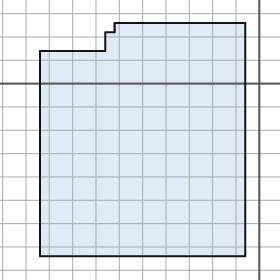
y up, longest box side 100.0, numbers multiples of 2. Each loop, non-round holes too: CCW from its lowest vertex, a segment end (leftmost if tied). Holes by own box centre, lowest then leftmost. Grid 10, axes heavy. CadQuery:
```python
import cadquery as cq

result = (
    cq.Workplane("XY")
    .moveTo(-94.0, -74.0)
    .lineTo(-6.0, -74.0)
    .lineTo(-6.0, 26.0)
    .lineTo(-62.0, 26.0)
    .lineTo(-62.0, 22.0)
    .lineTo(-66.0, 22.0)
    .lineTo(-66.0, 14.0)
    .lineTo(-94.0, 14.0)
    .close()
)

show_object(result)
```